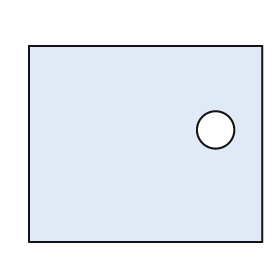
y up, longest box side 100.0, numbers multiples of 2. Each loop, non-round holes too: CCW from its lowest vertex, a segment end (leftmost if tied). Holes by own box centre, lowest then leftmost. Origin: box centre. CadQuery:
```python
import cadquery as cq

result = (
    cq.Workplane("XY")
    .moveTo(-50.0, -42.0)
    .lineTo(50.0, -42.0)
    .lineTo(50.0, 42.0)
    .lineTo(-50.0, 42.0)
    .close()
    .moveTo(30.0, 6.0)
    .circle(8.0)
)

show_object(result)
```